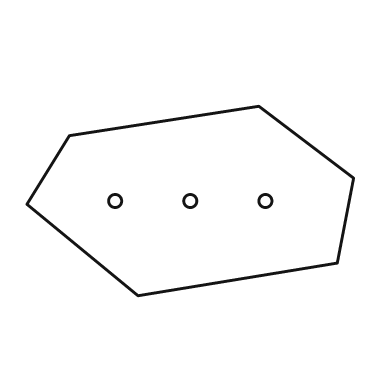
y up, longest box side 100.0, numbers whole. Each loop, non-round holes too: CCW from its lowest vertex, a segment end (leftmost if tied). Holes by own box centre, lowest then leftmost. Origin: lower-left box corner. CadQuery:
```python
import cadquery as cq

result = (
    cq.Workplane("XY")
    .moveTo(34.0, 0.0)
    .lineTo(95.0, 10.0)
    .lineTo(100.0, 36.0)
    .lineTo(71.0, 58.0)
    .lineTo(13.0, 49.0)
    .lineTo(0.0, 28.0)
    .close()
    .moveTo(27.0, 29.0)
    .circle(2.0)
    .moveTo(50.0, 29.0)
    .circle(2.0)
    .moveTo(73.0, 29.0)
    .circle(2.0)
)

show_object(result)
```